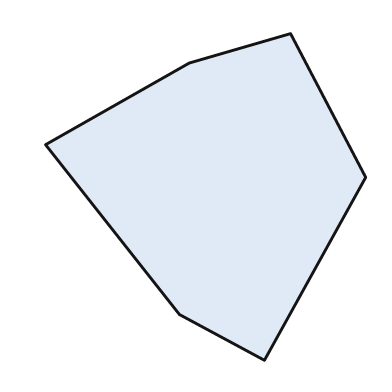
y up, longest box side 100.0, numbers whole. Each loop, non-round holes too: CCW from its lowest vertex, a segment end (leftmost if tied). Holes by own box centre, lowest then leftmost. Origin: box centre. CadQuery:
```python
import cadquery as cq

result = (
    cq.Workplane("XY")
    .moveTo(18.0, -50.0)
    .lineTo(49.0, 6.0)
    .lineTo(26.0, 50.0)
    .lineTo(-5.0, 41.0)
    .lineTo(-49.0, 16.0)
    .lineTo(-8.0, -36.0)
    .close()
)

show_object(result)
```